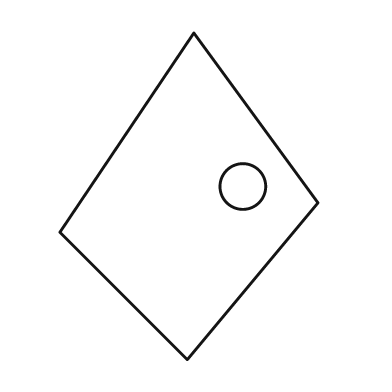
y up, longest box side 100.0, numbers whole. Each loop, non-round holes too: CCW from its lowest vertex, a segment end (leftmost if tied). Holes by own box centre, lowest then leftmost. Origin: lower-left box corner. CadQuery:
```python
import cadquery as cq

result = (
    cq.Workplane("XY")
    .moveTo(39.0, 0.0)
    .lineTo(79.0, 48.0)
    .lineTo(41.0, 100.0)
    .lineTo(0.0, 39.0)
    .close()
    .moveTo(56.0, 53.0)
    .circle(7.0)
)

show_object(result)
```